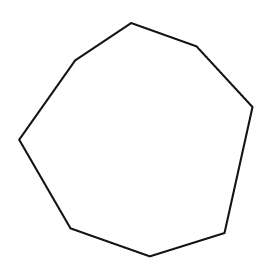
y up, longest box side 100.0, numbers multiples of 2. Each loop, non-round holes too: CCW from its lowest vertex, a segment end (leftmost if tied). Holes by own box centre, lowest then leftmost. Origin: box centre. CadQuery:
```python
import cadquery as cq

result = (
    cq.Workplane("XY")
    .moveTo(6.0, -50.0)
    .lineTo(38.0, -40.0)
    .lineTo(50.0, 14.0)
    .lineTo(26.0, 40.0)
    .lineTo(-2.0, 50.0)
    .lineTo(-26.0, 34.0)
    .lineTo(-50.0, 0.0)
    .lineTo(-28.0, -38.0)
    .close()
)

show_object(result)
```